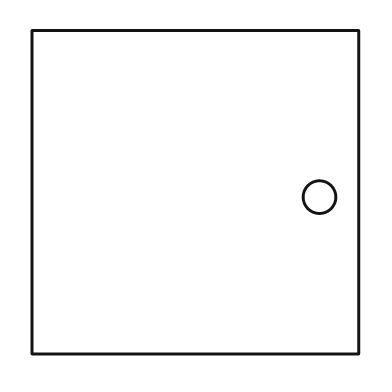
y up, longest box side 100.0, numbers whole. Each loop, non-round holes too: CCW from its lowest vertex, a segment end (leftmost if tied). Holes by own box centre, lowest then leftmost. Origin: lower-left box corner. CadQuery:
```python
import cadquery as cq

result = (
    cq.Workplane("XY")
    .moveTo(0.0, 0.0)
    .lineTo(100.0, 0.0)
    .lineTo(100.0, 99.0)
    .lineTo(0.0, 99.0)
    .close()
    .moveTo(88.0, 48.0)
    .circle(5.0)
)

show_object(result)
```